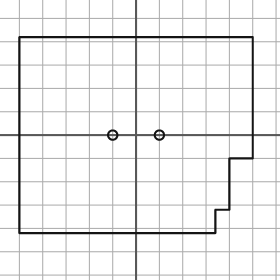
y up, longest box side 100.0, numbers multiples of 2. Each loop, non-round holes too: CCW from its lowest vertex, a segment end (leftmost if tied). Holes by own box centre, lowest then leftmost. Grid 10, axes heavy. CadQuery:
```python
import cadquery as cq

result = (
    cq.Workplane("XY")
    .moveTo(-50.0, -42.0)
    .lineTo(34.0, -42.0)
    .lineTo(34.0, -32.0)
    .lineTo(40.0, -32.0)
    .lineTo(40.0, -10.0)
    .lineTo(50.0, -10.0)
    .lineTo(50.0, 42.0)
    .lineTo(-50.0, 42.0)
    .close()
    .moveTo(-10.0, 0.0)
    .circle(2.0)
    .moveTo(10.0, 0.0)
    .circle(2.0)
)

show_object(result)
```